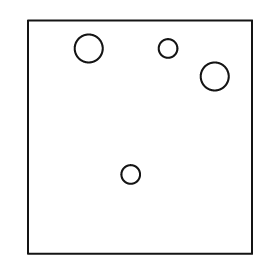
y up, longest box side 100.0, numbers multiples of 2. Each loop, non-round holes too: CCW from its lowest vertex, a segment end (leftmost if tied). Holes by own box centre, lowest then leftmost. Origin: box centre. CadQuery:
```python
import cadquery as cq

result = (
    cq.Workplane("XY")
    .moveTo(-48.0, -50.0)
    .lineTo(48.0, -50.0)
    .lineTo(48.0, 50.0)
    .lineTo(-48.0, 50.0)
    .close()
    .moveTo(-4.0, -16.0)
    .circle(4.0)
    .moveTo(32.0, 26.0)
    .circle(6.0)
    .moveTo(-22.0, 38.0)
    .circle(6.0)
    .moveTo(12.0, 38.0)
    .circle(4.0)
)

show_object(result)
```